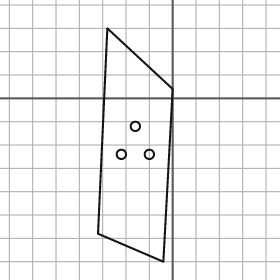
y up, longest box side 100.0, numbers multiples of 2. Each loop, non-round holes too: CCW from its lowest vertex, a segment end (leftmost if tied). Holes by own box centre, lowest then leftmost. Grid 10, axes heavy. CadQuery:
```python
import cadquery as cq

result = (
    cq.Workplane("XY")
    .moveTo(-4.0, -70.0)
    .lineTo(0.0, 4.0)
    .lineTo(-28.0, 30.0)
    .lineTo(-32.0, -58.0)
    .close()
    .moveTo(-22.0, -24.0)
    .circle(2.0)
    .moveTo(-10.0, -24.0)
    .circle(2.0)
    .moveTo(-16.0, -12.0)
    .circle(2.0)
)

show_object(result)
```